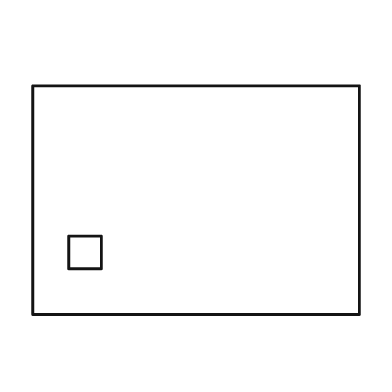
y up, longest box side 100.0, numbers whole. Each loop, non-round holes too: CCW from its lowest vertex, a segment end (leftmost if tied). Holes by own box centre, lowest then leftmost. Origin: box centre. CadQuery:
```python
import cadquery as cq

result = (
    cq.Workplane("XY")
    .moveTo(-50.0, -35.0)
    .lineTo(50.0, -35.0)
    .lineTo(50.0, 35.0)
    .lineTo(-50.0, 35.0)
    .close()
    .moveTo(-39.0, -21.0)
    .lineTo(-29.0, -21.0)
    .lineTo(-29.0, -11.0)
    .lineTo(-39.0, -11.0)
    .close()
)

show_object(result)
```